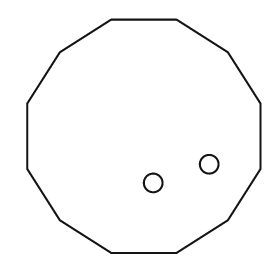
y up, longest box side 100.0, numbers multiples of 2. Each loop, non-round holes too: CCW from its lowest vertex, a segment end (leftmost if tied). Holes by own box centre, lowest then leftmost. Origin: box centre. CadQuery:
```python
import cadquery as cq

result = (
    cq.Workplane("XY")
    .moveTo(-14.0, -50.0)
    .lineTo(14.0, -50.0)
    .lineTo(36.0, -36.0)
    .lineTo(50.0, -14.0)
    .lineTo(50.0, 14.0)
    .lineTo(36.0, 36.0)
    .lineTo(14.0, 50.0)
    .lineTo(-14.0, 50.0)
    .lineTo(-36.0, 36.0)
    .lineTo(-50.0, 14.0)
    .lineTo(-50.0, -14.0)
    .lineTo(-36.0, -36.0)
    .close()
    .moveTo(4.0, -20.0)
    .circle(4.0)
    .moveTo(28.0, -12.0)
    .circle(4.0)
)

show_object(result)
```